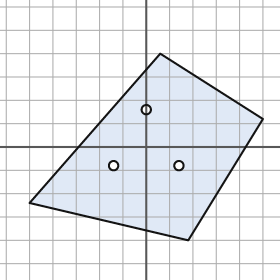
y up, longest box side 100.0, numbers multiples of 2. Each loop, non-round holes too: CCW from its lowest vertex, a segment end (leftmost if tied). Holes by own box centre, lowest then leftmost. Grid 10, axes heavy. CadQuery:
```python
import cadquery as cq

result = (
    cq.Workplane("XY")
    .moveTo(18.0, -40.0)
    .lineTo(50.0, 12.0)
    .lineTo(6.0, 40.0)
    .lineTo(-50.0, -24.0)
    .close()
    .moveTo(-14.0, -8.0)
    .circle(2.0)
    .moveTo(14.0, -8.0)
    .circle(2.0)
    .moveTo(0.0, 16.0)
    .circle(2.0)
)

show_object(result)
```